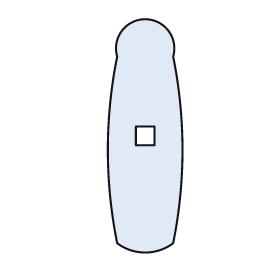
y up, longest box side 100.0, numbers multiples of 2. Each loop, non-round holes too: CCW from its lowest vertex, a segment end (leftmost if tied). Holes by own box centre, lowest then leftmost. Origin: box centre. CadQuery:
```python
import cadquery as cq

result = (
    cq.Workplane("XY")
    .moveTo(-12.0, -46.0)
    .threePointArc((0.0, -50.0), (12.0, -46.0))
    .threePointArc((16.0, -6.0), (12.0, 34.0))
    .threePointArc((0.0, 50.0), (-12.0, 34.0))
    .threePointArc((-16.0, -6.0), (-12.0, -46.0))
    .close()
    .moveTo(-4.0, -4.0)
    .lineTo(4.0, -4.0)
    .lineTo(4.0, 4.0)
    .lineTo(-4.0, 4.0)
    .close()
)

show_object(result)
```